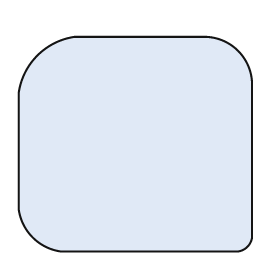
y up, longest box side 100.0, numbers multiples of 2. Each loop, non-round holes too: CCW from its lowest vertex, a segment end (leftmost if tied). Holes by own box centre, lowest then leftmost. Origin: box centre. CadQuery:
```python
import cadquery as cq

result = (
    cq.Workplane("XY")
    .moveTo(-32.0, -46.0)
    .lineTo(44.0, -46.0)
    .threePointArc((48.0, -44.0), (50.0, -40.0))
    .lineTo(50.0, 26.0)
    .threePointArc((44.0, 40.0), (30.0, 46.0))
    .lineTo(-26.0, 46.0)
    .threePointArc((-42.0, 38.0), (-50.0, 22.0))
    .lineTo(-50.0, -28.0)
    .threePointArc((-44.0, -40.0), (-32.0, -46.0))
    .close()
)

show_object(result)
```